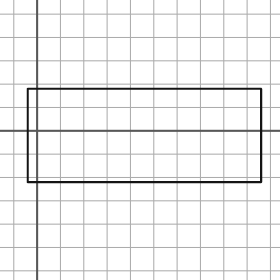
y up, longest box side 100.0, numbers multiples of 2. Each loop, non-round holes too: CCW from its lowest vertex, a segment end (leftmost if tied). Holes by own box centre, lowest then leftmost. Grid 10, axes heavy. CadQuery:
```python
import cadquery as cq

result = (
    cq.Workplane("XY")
    .moveTo(-4.0, -22.0)
    .lineTo(96.0, -22.0)
    .lineTo(96.0, 18.0)
    .lineTo(-4.0, 18.0)
    .close()
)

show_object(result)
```